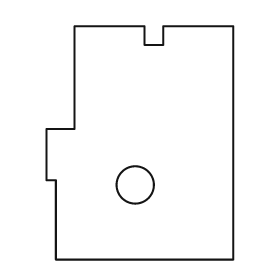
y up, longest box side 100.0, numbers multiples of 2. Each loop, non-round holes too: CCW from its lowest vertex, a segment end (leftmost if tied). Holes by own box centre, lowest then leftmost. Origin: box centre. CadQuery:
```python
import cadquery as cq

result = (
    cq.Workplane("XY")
    .moveTo(-36.0, -50.0)
    .lineTo(40.0, -50.0)
    .lineTo(40.0, 50.0)
    .lineTo(10.0, 50.0)
    .lineTo(10.0, 42.0)
    .lineTo(2.0, 42.0)
    .lineTo(2.0, 50.0)
    .lineTo(-28.0, 50.0)
    .lineTo(-28.0, 6.0)
    .lineTo(-40.0, 6.0)
    .lineTo(-40.0, -16.0)
    .lineTo(-36.0, -16.0)
    .close()
    .moveTo(-2.0, -18.0)
    .circle(8.0)
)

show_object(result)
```